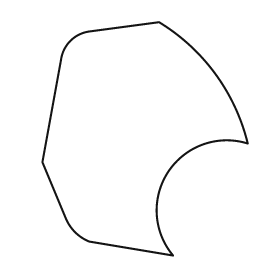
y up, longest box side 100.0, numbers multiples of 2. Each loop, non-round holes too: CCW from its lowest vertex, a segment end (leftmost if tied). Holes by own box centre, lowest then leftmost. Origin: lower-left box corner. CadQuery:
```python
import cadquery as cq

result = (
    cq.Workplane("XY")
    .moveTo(56.0, 0.0)
    .threePointArc((54.0, 36.0), (88.0, 48.0))
    .threePointArc((74.0, 78.0), (50.0, 100.0))
    .lineTo(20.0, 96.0)
    .threePointArc((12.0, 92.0), (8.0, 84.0))
    .lineTo(0.0, 40.0)
    .lineTo(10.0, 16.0)
    .threePointArc((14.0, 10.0), (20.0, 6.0))
    .close()
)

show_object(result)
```